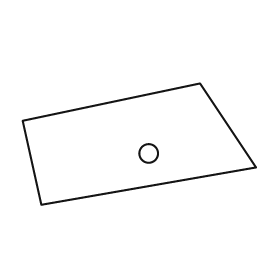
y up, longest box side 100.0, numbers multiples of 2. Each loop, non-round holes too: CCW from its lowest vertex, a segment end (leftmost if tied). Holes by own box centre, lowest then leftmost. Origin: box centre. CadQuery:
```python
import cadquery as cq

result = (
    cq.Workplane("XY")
    .moveTo(-42.0, -26.0)
    .lineTo(50.0, -10.0)
    .lineTo(26.0, 26.0)
    .lineTo(-50.0, 10.0)
    .close()
    .moveTo(4.0, -4.0)
    .circle(4.0)
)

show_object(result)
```